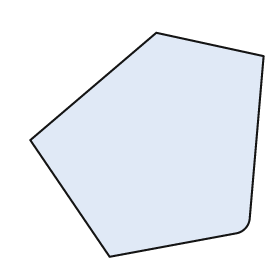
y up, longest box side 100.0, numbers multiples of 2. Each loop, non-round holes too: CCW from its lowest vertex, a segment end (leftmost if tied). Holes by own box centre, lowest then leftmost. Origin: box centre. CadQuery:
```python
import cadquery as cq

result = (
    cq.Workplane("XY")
    .moveTo(-16.0, -48.0)
    .lineTo(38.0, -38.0)
    .threePointArc((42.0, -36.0), (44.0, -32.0))
    .lineTo(50.0, 38.0)
    .lineTo(4.0, 48.0)
    .lineTo(-50.0, 2.0)
    .close()
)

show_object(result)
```